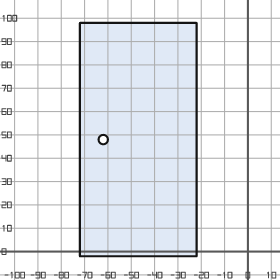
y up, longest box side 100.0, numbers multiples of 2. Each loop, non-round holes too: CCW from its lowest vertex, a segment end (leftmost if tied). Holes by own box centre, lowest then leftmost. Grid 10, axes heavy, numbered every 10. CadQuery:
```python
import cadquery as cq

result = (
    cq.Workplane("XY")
    .moveTo(-72.0, -2.0)
    .lineTo(-22.0, -2.0)
    .lineTo(-22.0, 98.0)
    .lineTo(-72.0, 98.0)
    .close()
    .moveTo(-62.0, 48.0)
    .circle(2.0)
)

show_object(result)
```